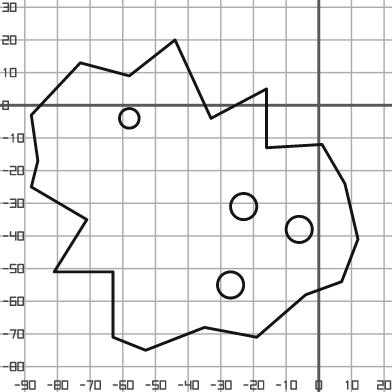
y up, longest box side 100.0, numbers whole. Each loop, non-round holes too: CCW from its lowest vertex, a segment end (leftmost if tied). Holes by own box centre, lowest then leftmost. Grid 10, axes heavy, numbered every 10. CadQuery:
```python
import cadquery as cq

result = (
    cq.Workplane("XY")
    .moveTo(-53.0, -75.0)
    .lineTo(-35.0, -68.0)
    .lineTo(-19.0, -71.0)
    .lineTo(-4.0, -58.0)
    .lineTo(7.0, -54.0)
    .lineTo(12.0, -41.0)
    .lineTo(8.0, -24.0)
    .lineTo(1.0, -12.0)
    .lineTo(-16.0, -13.0)
    .lineTo(-16.0, 5.0)
    .lineTo(-33.0, -4.0)
    .lineTo(-44.0, 20.0)
    .lineTo(-58.0, 9.0)
    .lineTo(-73.0, 13.0)
    .lineTo(-88.0, -3.0)
    .lineTo(-86.0, -17.0)
    .lineTo(-88.0, -25.0)
    .lineTo(-71.0, -35.0)
    .lineTo(-81.0, -51.0)
    .lineTo(-63.0, -51.0)
    .lineTo(-63.0, -71.0)
    .close()
    .moveTo(-27.0, -55.0)
    .circle(4.0)
    .moveTo(-6.0, -38.0)
    .circle(4.0)
    .moveTo(-23.0, -31.0)
    .circle(4.0)
    .moveTo(-58.0, -4.0)
    .circle(3.0)
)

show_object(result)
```